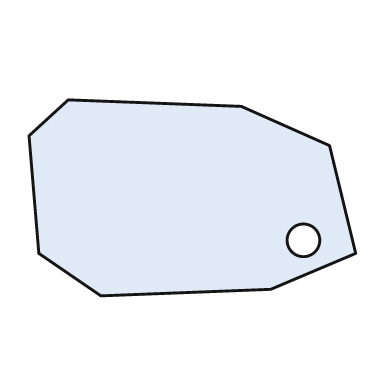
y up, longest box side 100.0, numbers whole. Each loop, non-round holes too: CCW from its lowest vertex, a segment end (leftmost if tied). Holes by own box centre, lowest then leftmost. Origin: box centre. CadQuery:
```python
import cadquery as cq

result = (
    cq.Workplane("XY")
    .moveTo(-28.0, -30.0)
    .lineTo(24.0, -28.0)
    .lineTo(50.0, -17.0)
    .lineTo(42.0, 16.0)
    .lineTo(15.0, 28.0)
    .lineTo(-38.0, 30.0)
    .lineTo(-50.0, 19.0)
    .lineTo(-47.0, -17.0)
    .close()
    .moveTo(34.0, -13.0)
    .circle(5.0)
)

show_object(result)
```